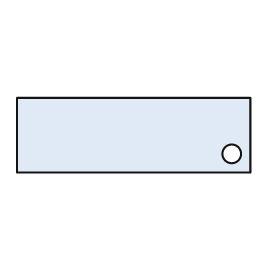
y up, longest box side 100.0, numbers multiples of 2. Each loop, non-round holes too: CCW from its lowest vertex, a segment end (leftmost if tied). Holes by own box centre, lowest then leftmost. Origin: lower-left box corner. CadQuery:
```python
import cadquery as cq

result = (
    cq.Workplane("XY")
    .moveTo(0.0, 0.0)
    .lineTo(100.0, 0.0)
    .lineTo(100.0, 32.0)
    .lineTo(0.0, 32.0)
    .close()
    .moveTo(92.0, 8.0)
    .circle(4.0)
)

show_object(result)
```